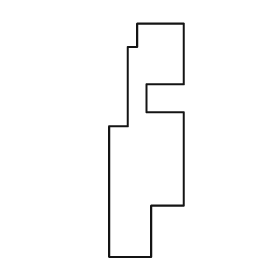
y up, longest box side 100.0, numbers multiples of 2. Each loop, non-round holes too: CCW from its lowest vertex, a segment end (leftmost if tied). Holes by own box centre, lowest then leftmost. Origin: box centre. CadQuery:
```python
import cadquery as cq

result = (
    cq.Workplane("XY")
    .moveTo(-16.0, -50.0)
    .lineTo(2.0, -50.0)
    .lineTo(2.0, -28.0)
    .lineTo(16.0, -28.0)
    .lineTo(16.0, 12.0)
    .lineTo(0.0, 12.0)
    .lineTo(0.0, 24.0)
    .lineTo(16.0, 24.0)
    .lineTo(16.0, 50.0)
    .lineTo(-4.0, 50.0)
    .lineTo(-4.0, 40.0)
    .lineTo(-8.0, 40.0)
    .lineTo(-8.0, 6.0)
    .lineTo(-16.0, 6.0)
    .close()
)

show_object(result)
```